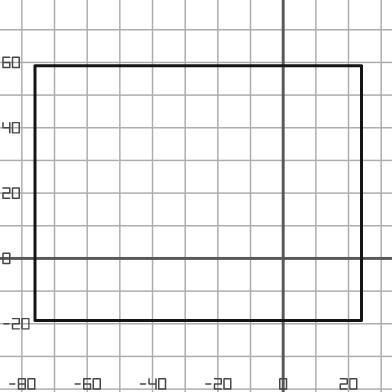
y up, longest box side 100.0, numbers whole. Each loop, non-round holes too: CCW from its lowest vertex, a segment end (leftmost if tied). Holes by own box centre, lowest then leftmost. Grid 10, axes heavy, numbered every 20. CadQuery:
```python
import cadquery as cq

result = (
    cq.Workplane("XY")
    .moveTo(-76.0, -19.0)
    .lineTo(24.0, -19.0)
    .lineTo(24.0, 59.0)
    .lineTo(-76.0, 59.0)
    .close()
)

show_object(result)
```